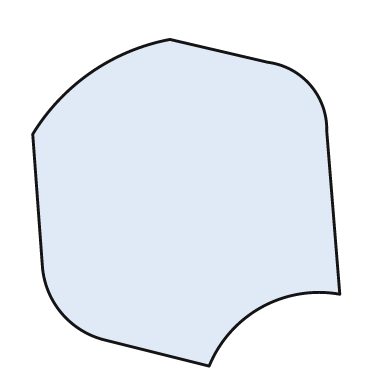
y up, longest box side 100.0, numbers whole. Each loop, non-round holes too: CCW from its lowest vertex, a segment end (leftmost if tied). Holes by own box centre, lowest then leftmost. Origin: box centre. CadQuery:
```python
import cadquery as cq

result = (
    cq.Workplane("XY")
    .moveTo(7.0, -50.0)
    .threePointArc((23.0, -32.0), (47.0, -28.0))
    .lineTo(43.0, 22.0)
    .threePointArc((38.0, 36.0), (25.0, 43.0))
    .lineTo(-5.0, 50.0)
    .threePointArc((-29.0, 40.0), (-47.0, 21.0))
    .lineTo(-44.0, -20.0)
    .threePointArc((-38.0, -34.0), (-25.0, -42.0))
    .close()
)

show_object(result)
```